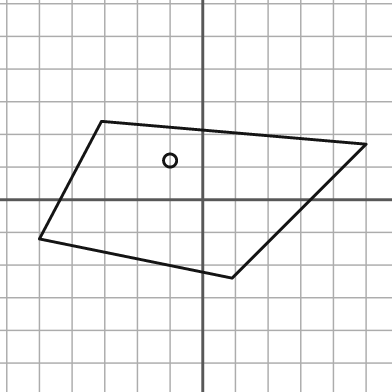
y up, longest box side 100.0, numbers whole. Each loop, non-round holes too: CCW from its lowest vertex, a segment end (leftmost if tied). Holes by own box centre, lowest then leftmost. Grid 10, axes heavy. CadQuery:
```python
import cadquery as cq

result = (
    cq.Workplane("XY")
    .moveTo(9.0, -24.0)
    .lineTo(50.0, 17.0)
    .lineTo(-31.0, 24.0)
    .lineTo(-50.0, -12.0)
    .close()
    .moveTo(-10.0, 12.0)
    .circle(2.0)
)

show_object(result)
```